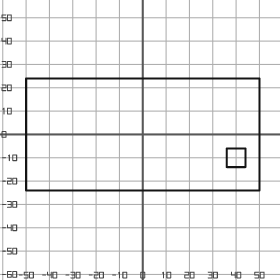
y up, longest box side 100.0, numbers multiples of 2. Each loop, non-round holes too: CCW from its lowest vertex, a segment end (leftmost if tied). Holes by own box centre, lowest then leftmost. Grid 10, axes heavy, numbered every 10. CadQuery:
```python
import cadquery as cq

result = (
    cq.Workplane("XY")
    .moveTo(-50.0, -24.0)
    .lineTo(50.0, -24.0)
    .lineTo(50.0, 24.0)
    .lineTo(-50.0, 24.0)
    .close()
    .moveTo(36.0, -14.0)
    .lineTo(44.0, -14.0)
    .lineTo(44.0, -6.0)
    .lineTo(36.0, -6.0)
    .close()
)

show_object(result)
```